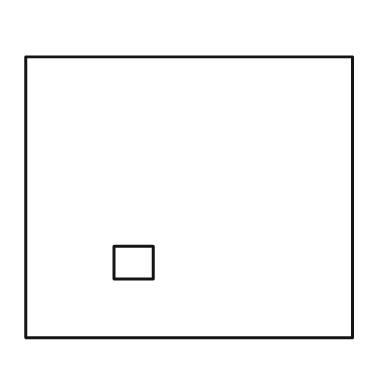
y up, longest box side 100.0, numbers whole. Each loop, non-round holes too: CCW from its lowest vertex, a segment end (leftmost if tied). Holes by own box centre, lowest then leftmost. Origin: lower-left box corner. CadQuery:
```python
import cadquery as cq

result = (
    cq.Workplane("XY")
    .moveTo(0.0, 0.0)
    .lineTo(100.0, 0.0)
    .lineTo(100.0, 86.0)
    .lineTo(0.0, 86.0)
    .close()
    .moveTo(27.0, 18.0)
    .lineTo(39.0, 18.0)
    .lineTo(39.0, 28.0)
    .lineTo(27.0, 28.0)
    .close()
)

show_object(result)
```